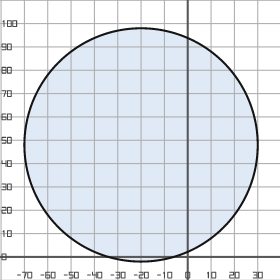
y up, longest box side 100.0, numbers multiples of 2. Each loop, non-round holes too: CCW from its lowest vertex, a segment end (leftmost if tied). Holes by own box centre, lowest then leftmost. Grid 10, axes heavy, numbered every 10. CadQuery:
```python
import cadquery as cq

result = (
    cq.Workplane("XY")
    .moveTo(-20.0, 48.0)
    .circle(50.0)
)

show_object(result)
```